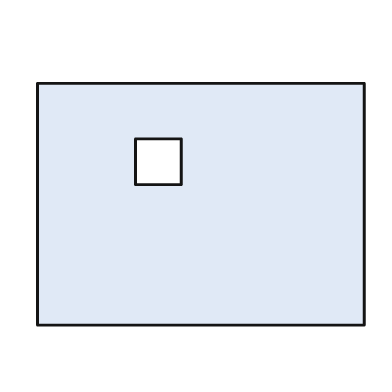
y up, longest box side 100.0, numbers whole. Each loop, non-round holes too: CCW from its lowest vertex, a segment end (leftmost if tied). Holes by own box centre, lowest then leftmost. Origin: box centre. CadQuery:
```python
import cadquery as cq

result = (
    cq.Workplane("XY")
    .moveTo(-50.0, -37.0)
    .lineTo(50.0, -37.0)
    .lineTo(50.0, 37.0)
    .lineTo(-50.0, 37.0)
    .close()
    .moveTo(-20.0, 6.0)
    .lineTo(-6.0, 6.0)
    .lineTo(-6.0, 20.0)
    .lineTo(-20.0, 20.0)
    .close()
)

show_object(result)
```